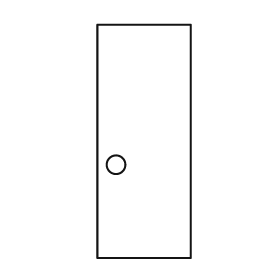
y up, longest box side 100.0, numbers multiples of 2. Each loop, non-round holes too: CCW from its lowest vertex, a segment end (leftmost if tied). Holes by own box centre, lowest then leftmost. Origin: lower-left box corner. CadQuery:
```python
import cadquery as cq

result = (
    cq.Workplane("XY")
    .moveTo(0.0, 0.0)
    .lineTo(40.0, 0.0)
    .lineTo(40.0, 100.0)
    .lineTo(0.0, 100.0)
    .close()
    .moveTo(8.0, 40.0)
    .circle(4.0)
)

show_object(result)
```